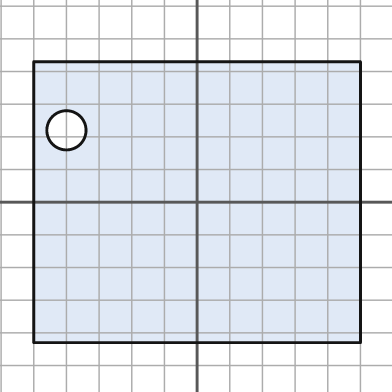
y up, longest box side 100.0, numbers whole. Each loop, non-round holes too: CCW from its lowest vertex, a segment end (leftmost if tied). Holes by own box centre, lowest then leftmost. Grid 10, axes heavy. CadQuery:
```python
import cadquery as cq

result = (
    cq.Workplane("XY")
    .moveTo(-50.0, -43.0)
    .lineTo(50.0, -43.0)
    .lineTo(50.0, 43.0)
    .lineTo(-50.0, 43.0)
    .close()
    .moveTo(-40.0, 22.0)
    .circle(6.0)
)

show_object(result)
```